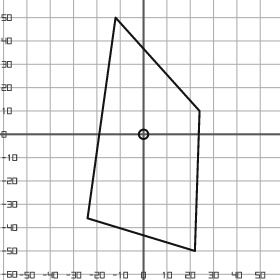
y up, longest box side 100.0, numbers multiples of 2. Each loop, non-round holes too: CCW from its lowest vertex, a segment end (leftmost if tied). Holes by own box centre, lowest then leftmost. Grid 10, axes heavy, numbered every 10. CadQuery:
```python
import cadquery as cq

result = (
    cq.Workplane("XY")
    .moveTo(22.0, -50.0)
    .lineTo(24.0, 10.0)
    .lineTo(-12.0, 50.0)
    .lineTo(-24.0, -36.0)
    .close()
    .moveTo(0.0, 0.0)
    .circle(2.0)
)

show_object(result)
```